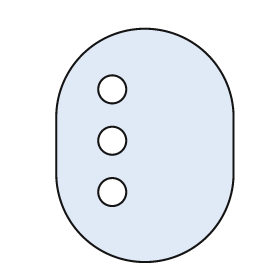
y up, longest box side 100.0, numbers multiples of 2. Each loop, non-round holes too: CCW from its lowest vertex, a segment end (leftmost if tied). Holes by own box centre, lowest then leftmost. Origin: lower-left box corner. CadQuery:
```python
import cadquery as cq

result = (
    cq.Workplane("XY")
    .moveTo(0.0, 38.0)
    .threePointArc((38.0, 0.0), (76.0, 38.0))
    .lineTo(76.0, 62.0)
    .threePointArc((38.0, 100.0), (0.0, 62.0))
    .close()
    .moveTo(24.0, 30.0)
    .circle(6.0)
    .moveTo(24.0, 52.0)
    .circle(6.0)
    .moveTo(24.0, 74.0)
    .circle(6.0)
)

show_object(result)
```